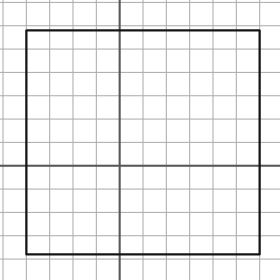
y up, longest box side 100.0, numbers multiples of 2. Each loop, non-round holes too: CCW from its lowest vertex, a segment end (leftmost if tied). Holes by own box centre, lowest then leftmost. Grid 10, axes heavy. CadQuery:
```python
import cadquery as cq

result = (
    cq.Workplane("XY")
    .moveTo(-40.0, -38.0)
    .lineTo(60.0, -38.0)
    .lineTo(60.0, 58.0)
    .lineTo(-40.0, 58.0)
    .close()
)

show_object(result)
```